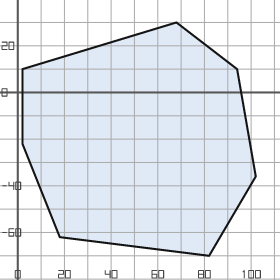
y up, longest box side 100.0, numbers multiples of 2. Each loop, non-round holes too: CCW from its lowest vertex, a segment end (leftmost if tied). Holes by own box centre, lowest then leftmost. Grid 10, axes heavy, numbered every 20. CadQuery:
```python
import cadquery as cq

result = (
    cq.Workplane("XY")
    .moveTo(82.0, -70.0)
    .lineTo(102.0, -36.0)
    .lineTo(94.0, 10.0)
    .lineTo(68.0, 30.0)
    .lineTo(2.0, 10.0)
    .lineTo(2.0, -22.0)
    .lineTo(18.0, -62.0)
    .close()
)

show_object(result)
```